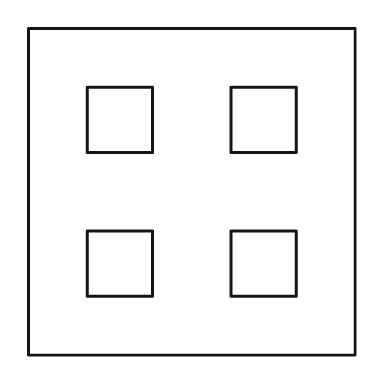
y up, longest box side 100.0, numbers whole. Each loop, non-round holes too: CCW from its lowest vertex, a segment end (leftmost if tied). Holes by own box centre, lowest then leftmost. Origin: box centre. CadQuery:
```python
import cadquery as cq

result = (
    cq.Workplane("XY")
    .moveTo(-50.0, -50.0)
    .lineTo(50.0, -50.0)
    .lineTo(50.0, 50.0)
    .lineTo(-50.0, 50.0)
    .close()
    .moveTo(-32.0, -32.0)
    .lineTo(-12.0, -32.0)
    .lineTo(-12.0, -12.0)
    .lineTo(-32.0, -12.0)
    .close()
    .moveTo(12.0, -32.0)
    .lineTo(32.0, -32.0)
    .lineTo(32.0, -12.0)
    .lineTo(12.0, -12.0)
    .close()
    .moveTo(-32.0, 12.0)
    .lineTo(-12.0, 12.0)
    .lineTo(-12.0, 32.0)
    .lineTo(-32.0, 32.0)
    .close()
    .moveTo(12.0, 12.0)
    .lineTo(32.0, 12.0)
    .lineTo(32.0, 32.0)
    .lineTo(12.0, 32.0)
    .close()
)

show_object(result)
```